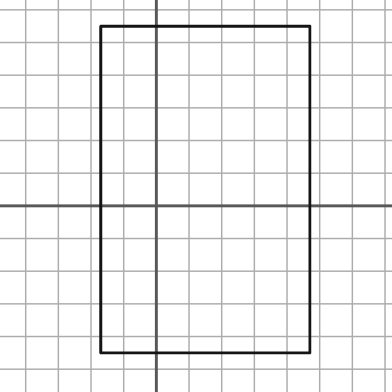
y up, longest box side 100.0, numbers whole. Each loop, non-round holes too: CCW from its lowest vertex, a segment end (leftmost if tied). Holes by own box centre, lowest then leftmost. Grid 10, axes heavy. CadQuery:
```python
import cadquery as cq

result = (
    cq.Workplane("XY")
    .moveTo(-17.0, -45.0)
    .lineTo(47.0, -45.0)
    .lineTo(47.0, 55.0)
    .lineTo(-17.0, 55.0)
    .close()
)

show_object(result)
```